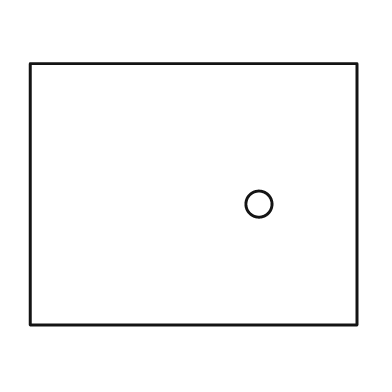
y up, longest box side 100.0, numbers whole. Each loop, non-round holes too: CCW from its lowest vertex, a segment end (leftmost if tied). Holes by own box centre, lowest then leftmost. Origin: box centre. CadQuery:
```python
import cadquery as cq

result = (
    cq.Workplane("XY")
    .moveTo(-50.0, -40.0)
    .lineTo(50.0, -40.0)
    .lineTo(50.0, 40.0)
    .lineTo(-50.0, 40.0)
    .close()
    .moveTo(20.0, -3.0)
    .circle(4.0)
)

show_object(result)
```